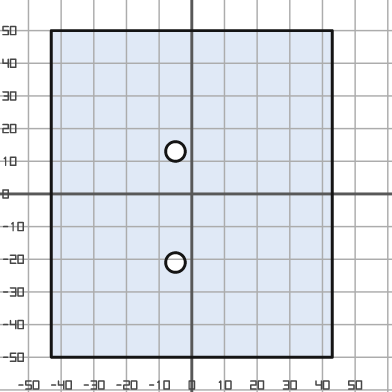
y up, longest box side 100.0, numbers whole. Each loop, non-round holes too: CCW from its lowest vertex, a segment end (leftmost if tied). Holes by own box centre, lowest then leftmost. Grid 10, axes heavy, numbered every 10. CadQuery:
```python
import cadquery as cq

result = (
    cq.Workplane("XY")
    .moveTo(-43.0, -50.0)
    .lineTo(43.0, -50.0)
    .lineTo(43.0, 50.0)
    .lineTo(-43.0, 50.0)
    .close()
    .moveTo(-5.0, -21.0)
    .circle(3.0)
    .moveTo(-5.0, 13.0)
    .circle(3.0)
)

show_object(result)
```